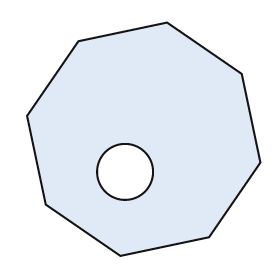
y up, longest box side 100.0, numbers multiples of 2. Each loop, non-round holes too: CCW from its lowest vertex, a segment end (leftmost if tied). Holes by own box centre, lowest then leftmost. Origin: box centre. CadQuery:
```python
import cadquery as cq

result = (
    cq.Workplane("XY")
    .moveTo(-10.0, -50.0)
    .lineTo(28.0, -42.0)
    .lineTo(50.0, -10.0)
    .lineTo(42.0, 28.0)
    .lineTo(10.0, 50.0)
    .lineTo(-28.0, 42.0)
    .lineTo(-50.0, 10.0)
    .lineTo(-42.0, -28.0)
    .close()
    .moveTo(-8.0, -14.0)
    .circle(12.0)
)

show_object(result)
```